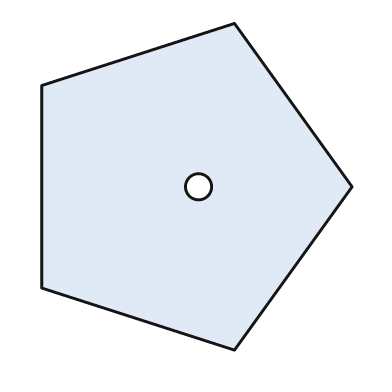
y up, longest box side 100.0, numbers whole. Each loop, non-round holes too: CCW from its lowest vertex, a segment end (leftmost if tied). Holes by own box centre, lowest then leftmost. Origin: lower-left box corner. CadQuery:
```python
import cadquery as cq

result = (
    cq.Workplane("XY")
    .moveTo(59.0, 0.0)
    .lineTo(95.0, 50.0)
    .lineTo(59.0, 100.0)
    .lineTo(0.0, 81.0)
    .lineTo(0.0, 19.0)
    .close()
    .moveTo(48.0, 50.0)
    .circle(4.0)
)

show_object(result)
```